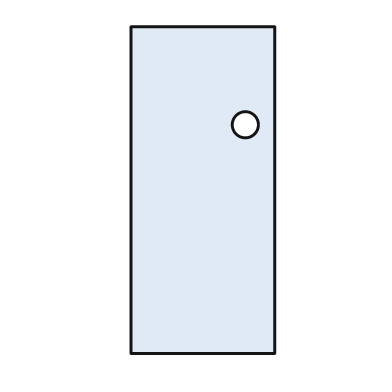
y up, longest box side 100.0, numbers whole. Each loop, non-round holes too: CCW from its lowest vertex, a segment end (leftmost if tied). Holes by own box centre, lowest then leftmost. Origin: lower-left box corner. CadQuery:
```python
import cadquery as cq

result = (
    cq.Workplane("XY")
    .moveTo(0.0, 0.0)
    .lineTo(44.0, 0.0)
    .lineTo(44.0, 100.0)
    .lineTo(0.0, 100.0)
    .close()
    .moveTo(35.0, 70.0)
    .circle(4.0)
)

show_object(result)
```